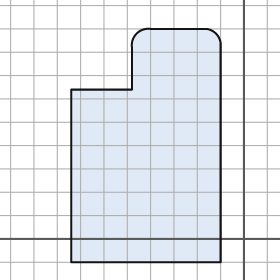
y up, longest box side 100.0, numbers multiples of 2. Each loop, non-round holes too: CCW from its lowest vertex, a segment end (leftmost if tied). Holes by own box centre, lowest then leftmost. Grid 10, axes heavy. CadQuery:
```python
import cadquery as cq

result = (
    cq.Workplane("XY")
    .moveTo(-74.0, -10.0)
    .lineTo(-10.0, -10.0)
    .lineTo(-10.0, 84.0)
    .threePointArc((-12.0, 88.0), (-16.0, 90.0))
    .lineTo(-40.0, 90.0)
    .threePointArc((-46.0, 88.0), (-48.0, 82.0))
    .lineTo(-48.0, 64.0)
    .lineTo(-74.0, 64.0)
    .close()
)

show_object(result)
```